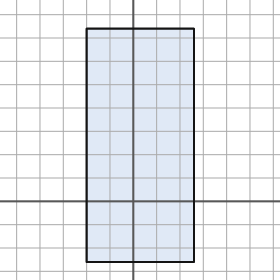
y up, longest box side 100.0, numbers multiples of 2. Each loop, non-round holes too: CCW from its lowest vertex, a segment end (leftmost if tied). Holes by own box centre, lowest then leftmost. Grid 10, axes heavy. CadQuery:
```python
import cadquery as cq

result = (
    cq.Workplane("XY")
    .moveTo(-20.0, -26.0)
    .lineTo(26.0, -26.0)
    .lineTo(26.0, 74.0)
    .lineTo(-20.0, 74.0)
    .close()
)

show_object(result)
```